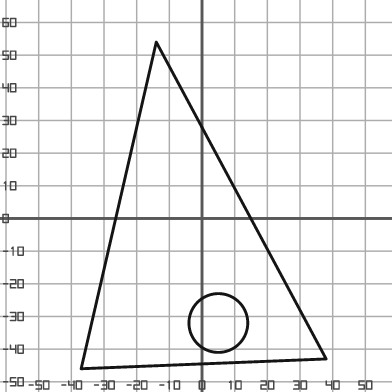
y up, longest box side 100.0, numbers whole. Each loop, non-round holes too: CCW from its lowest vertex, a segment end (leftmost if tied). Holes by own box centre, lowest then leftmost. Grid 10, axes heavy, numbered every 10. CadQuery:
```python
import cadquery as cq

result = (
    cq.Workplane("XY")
    .moveTo(-37.0, -46.0)
    .lineTo(38.0, -43.0)
    .lineTo(-14.0, 54.0)
    .close()
    .moveTo(5.0, -32.0)
    .circle(9.0)
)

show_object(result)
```